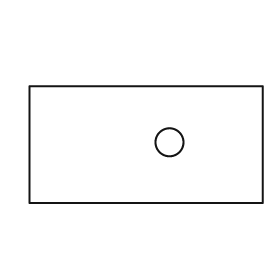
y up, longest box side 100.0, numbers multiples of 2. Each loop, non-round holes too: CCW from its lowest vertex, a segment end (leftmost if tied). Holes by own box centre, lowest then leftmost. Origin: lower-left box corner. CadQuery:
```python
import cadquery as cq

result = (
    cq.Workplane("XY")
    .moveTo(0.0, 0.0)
    .lineTo(100.0, 0.0)
    .lineTo(100.0, 50.0)
    .lineTo(0.0, 50.0)
    .close()
    .moveTo(60.0, 26.0)
    .circle(6.0)
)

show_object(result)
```